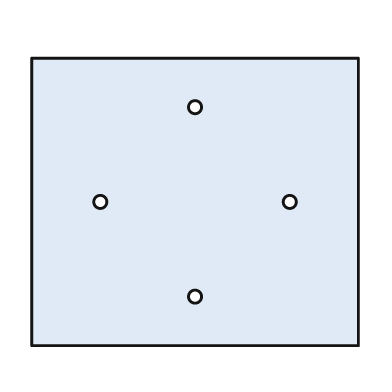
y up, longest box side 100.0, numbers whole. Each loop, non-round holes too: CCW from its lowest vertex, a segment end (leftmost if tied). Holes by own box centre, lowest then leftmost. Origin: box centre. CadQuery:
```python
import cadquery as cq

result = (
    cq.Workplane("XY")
    .moveTo(-50.0, -44.0)
    .lineTo(50.0, -44.0)
    .lineTo(50.0, 44.0)
    .lineTo(-50.0, 44.0)
    .close()
    .moveTo(0.0, -29.0)
    .circle(2.0)
    .moveTo(-29.0, 0.0)
    .circle(2.0)
    .moveTo(29.0, 0.0)
    .circle(2.0)
    .moveTo(0.0, 29.0)
    .circle(2.0)
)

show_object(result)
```